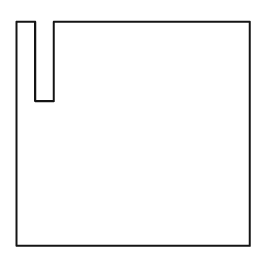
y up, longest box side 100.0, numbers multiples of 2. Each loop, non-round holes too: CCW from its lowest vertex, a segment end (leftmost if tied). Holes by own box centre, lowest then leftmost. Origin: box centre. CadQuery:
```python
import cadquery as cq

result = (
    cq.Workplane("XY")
    .moveTo(-50.0, -48.0)
    .lineTo(50.0, -48.0)
    .lineTo(50.0, 48.0)
    .lineTo(-34.0, 48.0)
    .lineTo(-34.0, 14.0)
    .lineTo(-42.0, 14.0)
    .lineTo(-42.0, 48.0)
    .lineTo(-50.0, 48.0)
    .close()
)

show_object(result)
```